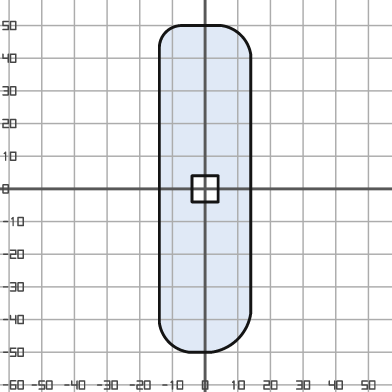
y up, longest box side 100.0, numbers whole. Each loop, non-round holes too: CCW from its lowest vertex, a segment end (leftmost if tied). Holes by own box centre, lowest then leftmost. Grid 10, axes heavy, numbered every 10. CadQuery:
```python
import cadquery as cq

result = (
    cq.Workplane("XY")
    .moveTo(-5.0, -50.0)
    .lineTo(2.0, -50.0)
    .threePointArc((10.0, -46.0), (14.0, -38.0))
    .lineTo(14.0, 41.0)
    .threePointArc((11.0, 47.0), (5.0, 50.0))
    .lineTo(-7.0, 50.0)
    .threePointArc((-12.0, 48.0), (-14.0, 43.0))
    .lineTo(-14.0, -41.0)
    .threePointArc((-11.0, -47.0), (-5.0, -50.0))
    .close()
    .moveTo(-4.0, -4.0)
    .lineTo(4.0, -4.0)
    .lineTo(4.0, 4.0)
    .lineTo(-4.0, 4.0)
    .close()
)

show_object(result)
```